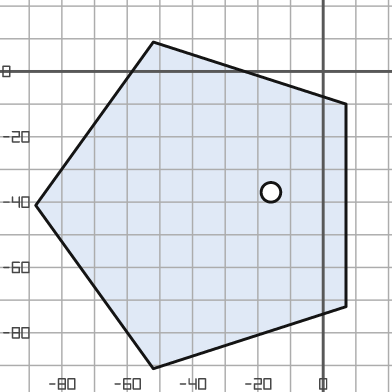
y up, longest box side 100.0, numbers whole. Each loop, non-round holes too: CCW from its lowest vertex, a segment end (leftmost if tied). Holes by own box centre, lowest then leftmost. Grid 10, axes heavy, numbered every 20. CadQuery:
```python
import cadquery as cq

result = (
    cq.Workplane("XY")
    .moveTo(-52.0, -91.0)
    .lineTo(7.0, -72.0)
    .lineTo(7.0, -10.0)
    .lineTo(-52.0, 9.0)
    .lineTo(-88.0, -41.0)
    .close()
    .moveTo(-16.0, -37.0)
    .circle(3.0)
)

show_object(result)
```